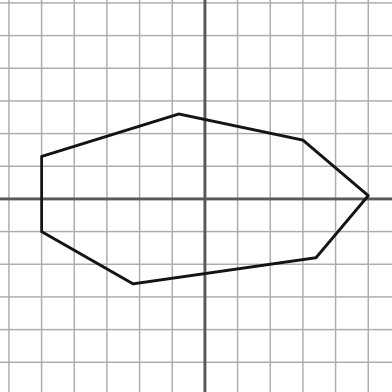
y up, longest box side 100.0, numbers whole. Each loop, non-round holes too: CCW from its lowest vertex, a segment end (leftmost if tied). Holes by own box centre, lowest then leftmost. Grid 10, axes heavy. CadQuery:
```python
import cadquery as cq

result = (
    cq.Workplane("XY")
    .moveTo(-22.0, -26.0)
    .lineTo(34.0, -18.0)
    .lineTo(50.0, 1.0)
    .lineTo(30.0, 18.0)
    .lineTo(-8.0, 26.0)
    .lineTo(-50.0, 13.0)
    .lineTo(-50.0, -10.0)
    .close()
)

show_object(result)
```